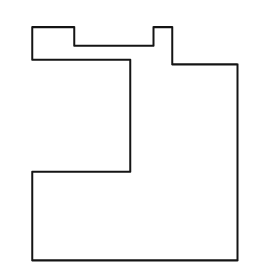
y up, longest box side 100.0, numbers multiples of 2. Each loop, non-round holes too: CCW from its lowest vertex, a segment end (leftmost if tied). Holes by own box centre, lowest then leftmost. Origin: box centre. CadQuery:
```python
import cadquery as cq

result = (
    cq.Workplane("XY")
    .moveTo(-44.0, -50.0)
    .lineTo(44.0, -50.0)
    .lineTo(44.0, 34.0)
    .lineTo(16.0, 34.0)
    .lineTo(16.0, 50.0)
    .lineTo(8.0, 50.0)
    .lineTo(8.0, 42.0)
    .lineTo(-26.0, 42.0)
    .lineTo(-26.0, 50.0)
    .lineTo(-44.0, 50.0)
    .lineTo(-44.0, 36.0)
    .lineTo(-2.0, 36.0)
    .lineTo(-2.0, -12.0)
    .lineTo(-44.0, -12.0)
    .close()
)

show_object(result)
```